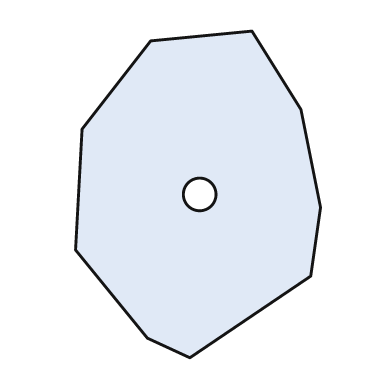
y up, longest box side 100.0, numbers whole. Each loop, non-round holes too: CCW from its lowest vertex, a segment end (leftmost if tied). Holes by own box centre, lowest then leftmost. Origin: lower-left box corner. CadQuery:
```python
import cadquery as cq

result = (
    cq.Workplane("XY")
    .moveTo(35.0, 0.0)
    .lineTo(72.0, 25.0)
    .lineTo(75.0, 46.0)
    .lineTo(69.0, 76.0)
    .lineTo(54.0, 100.0)
    .lineTo(23.0, 97.0)
    .lineTo(2.0, 70.0)
    .lineTo(0.0, 33.0)
    .lineTo(22.0, 6.0)
    .close()
    .moveTo(38.0, 50.0)
    .circle(5.0)
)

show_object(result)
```